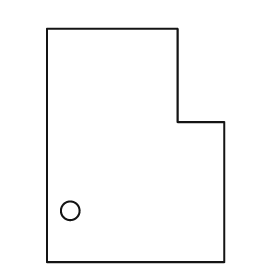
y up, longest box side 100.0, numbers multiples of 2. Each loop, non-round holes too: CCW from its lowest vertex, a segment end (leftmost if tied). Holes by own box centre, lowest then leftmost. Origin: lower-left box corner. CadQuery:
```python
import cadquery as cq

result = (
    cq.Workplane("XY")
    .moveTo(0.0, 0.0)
    .lineTo(76.0, 0.0)
    .lineTo(76.0, 60.0)
    .lineTo(56.0, 60.0)
    .lineTo(56.0, 100.0)
    .lineTo(0.0, 100.0)
    .close()
    .moveTo(10.0, 22.0)
    .circle(4.0)
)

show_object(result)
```